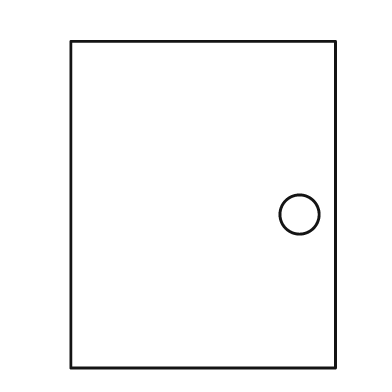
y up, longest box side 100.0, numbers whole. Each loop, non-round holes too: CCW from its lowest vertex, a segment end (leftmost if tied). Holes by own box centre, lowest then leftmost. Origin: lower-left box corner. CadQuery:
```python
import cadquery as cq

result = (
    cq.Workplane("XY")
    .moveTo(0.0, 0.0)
    .lineTo(81.0, 0.0)
    .lineTo(81.0, 100.0)
    .lineTo(0.0, 100.0)
    .close()
    .moveTo(70.0, 47.0)
    .circle(6.0)
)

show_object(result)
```